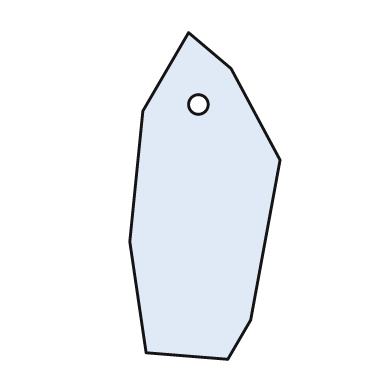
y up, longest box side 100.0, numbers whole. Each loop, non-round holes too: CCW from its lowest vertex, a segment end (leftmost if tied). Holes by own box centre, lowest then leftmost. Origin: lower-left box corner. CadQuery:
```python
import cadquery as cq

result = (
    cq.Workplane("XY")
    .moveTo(30.0, 0.0)
    .lineTo(37.0, 12.0)
    .lineTo(46.0, 61.0)
    .lineTo(31.0, 89.0)
    .lineTo(18.0, 100.0)
    .lineTo(4.0, 76.0)
    .lineTo(0.0, 36.0)
    .lineTo(5.0, 2.0)
    .close()
    .moveTo(21.0, 78.0)
    .circle(3.0)
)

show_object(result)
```